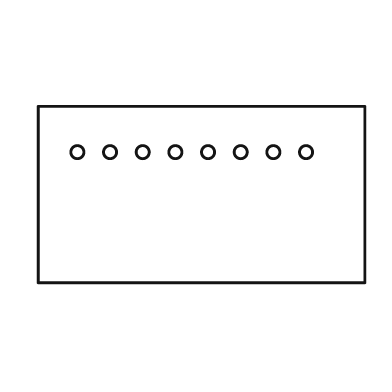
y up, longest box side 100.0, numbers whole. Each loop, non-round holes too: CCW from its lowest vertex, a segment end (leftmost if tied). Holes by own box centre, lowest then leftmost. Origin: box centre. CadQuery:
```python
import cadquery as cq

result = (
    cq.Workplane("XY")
    .moveTo(-50.0, -27.0)
    .lineTo(50.0, -27.0)
    .lineTo(50.0, 27.0)
    .lineTo(-50.0, 27.0)
    .close()
    .moveTo(-38.0, 13.0)
    .circle(2.0)
    .moveTo(-28.0, 13.0)
    .circle(2.0)
    .moveTo(-18.0, 13.0)
    .circle(2.0)
    .moveTo(-8.0, 13.0)
    .circle(2.0)
    .moveTo(2.0, 13.0)
    .circle(2.0)
    .moveTo(12.0, 13.0)
    .circle(2.0)
    .moveTo(22.0, 13.0)
    .circle(2.0)
    .moveTo(32.0, 13.0)
    .circle(2.0)
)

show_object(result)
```